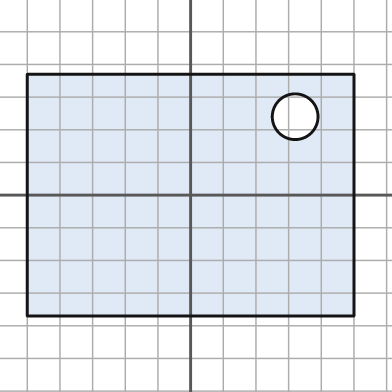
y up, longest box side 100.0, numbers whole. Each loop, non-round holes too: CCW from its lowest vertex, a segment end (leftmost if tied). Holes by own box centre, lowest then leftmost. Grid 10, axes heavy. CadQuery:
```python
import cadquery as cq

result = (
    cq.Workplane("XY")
    .moveTo(-50.0, -37.0)
    .lineTo(50.0, -37.0)
    .lineTo(50.0, 37.0)
    .lineTo(-50.0, 37.0)
    .close()
    .moveTo(32.0, 24.0)
    .circle(7.0)
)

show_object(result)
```